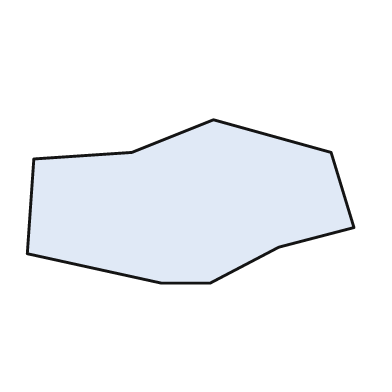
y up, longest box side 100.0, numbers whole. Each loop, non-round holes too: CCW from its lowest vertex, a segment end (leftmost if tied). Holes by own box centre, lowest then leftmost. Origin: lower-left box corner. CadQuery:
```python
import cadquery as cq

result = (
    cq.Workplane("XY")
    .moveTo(41.0, 0.0)
    .lineTo(56.0, 0.0)
    .lineTo(77.0, 11.0)
    .lineTo(100.0, 17.0)
    .lineTo(93.0, 40.0)
    .lineTo(57.0, 50.0)
    .lineTo(32.0, 40.0)
    .lineTo(2.0, 38.0)
    .lineTo(0.0, 9.0)
    .close()
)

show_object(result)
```